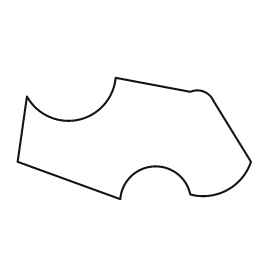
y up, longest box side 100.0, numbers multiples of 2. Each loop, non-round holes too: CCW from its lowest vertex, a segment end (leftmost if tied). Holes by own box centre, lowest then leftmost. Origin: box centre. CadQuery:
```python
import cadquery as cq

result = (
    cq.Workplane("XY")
    .moveTo(-6.0, -26.0)
    .threePointArc((8.0, -12.0), (24.0, -24.0))
    .threePointArc((40.0, -22.0), (50.0, -10.0))
    .lineTo(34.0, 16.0)
    .threePointArc((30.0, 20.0), (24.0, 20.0))
    .lineTo(-8.0, 26.0)
    .threePointArc((-24.0, 8.0), (-46.0, 18.0))
    .lineTo(-50.0, -10.0)
    .close()
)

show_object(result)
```